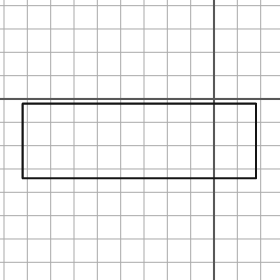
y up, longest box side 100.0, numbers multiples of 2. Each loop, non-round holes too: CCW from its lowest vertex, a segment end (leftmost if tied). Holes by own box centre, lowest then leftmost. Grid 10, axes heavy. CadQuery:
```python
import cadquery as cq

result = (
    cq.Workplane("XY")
    .moveTo(-82.0, -34.0)
    .lineTo(18.0, -34.0)
    .lineTo(18.0, -2.0)
    .lineTo(-82.0, -2.0)
    .close()
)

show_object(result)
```